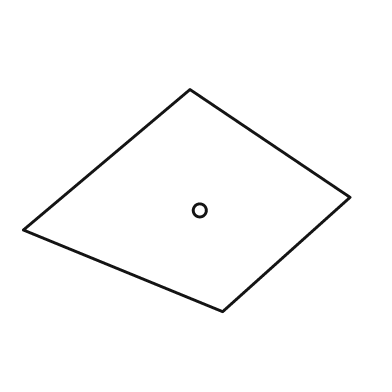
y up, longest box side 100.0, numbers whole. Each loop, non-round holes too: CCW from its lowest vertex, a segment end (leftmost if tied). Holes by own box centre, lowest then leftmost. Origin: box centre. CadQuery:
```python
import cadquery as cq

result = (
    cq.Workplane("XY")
    .moveTo(11.0, -34.0)
    .lineTo(50.0, 1.0)
    .lineTo(1.0, 34.0)
    .lineTo(-50.0, -9.0)
    .close()
    .moveTo(4.0, -3.0)
    .circle(2.0)
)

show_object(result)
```